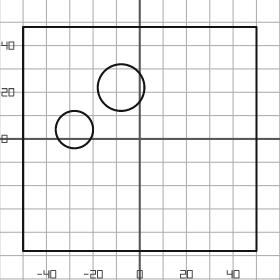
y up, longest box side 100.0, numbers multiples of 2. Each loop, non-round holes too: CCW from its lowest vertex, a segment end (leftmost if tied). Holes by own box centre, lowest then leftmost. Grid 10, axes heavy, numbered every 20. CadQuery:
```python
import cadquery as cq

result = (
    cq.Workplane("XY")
    .moveTo(-50.0, -48.0)
    .lineTo(50.0, -48.0)
    .lineTo(50.0, 48.0)
    .lineTo(-50.0, 48.0)
    .close()
    .moveTo(-28.0, 4.0)
    .circle(8.0)
    .moveTo(-8.0, 22.0)
    .circle(10.0)
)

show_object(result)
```